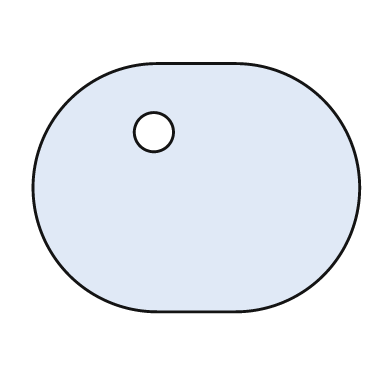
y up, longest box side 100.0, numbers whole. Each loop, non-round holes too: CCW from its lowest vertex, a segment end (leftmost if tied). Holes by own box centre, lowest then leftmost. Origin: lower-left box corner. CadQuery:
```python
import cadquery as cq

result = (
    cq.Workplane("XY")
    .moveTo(38.0, 0.0)
    .lineTo(62.0, 0.0)
    .threePointArc((100.0, 38.0), (62.0, 76.0))
    .lineTo(38.0, 76.0)
    .threePointArc((0.0, 38.0), (38.0, 0.0))
    .close()
    .moveTo(37.0, 55.0)
    .circle(6.0)
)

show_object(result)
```